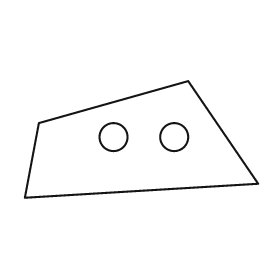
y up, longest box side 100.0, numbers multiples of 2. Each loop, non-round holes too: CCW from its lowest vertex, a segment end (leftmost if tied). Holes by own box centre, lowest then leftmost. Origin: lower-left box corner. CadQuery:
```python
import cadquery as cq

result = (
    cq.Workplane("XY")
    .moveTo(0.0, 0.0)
    .lineTo(100.0, 6.0)
    .lineTo(70.0, 50.0)
    .lineTo(6.0, 32.0)
    .close()
    .moveTo(38.0, 26.0)
    .circle(6.0)
    .moveTo(64.0, 26.0)
    .circle(6.0)
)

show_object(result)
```